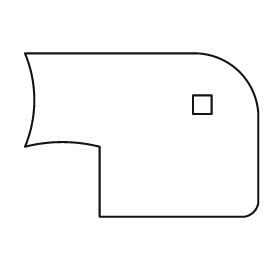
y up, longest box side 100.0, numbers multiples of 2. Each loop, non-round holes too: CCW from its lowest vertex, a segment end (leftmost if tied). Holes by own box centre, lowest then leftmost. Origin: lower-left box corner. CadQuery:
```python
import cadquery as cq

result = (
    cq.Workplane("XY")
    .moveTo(32.0, 0.0)
    .lineTo(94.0, 0.0)
    .threePointArc((98.0, 2.0), (100.0, 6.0))
    .lineTo(100.0, 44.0)
    .threePointArc((92.0, 62.0), (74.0, 70.0))
    .lineTo(0.0, 70.0)
    .threePointArc((4.0, 50.0), (0.0, 30.0))
    .threePointArc((16.0, 32.0), (32.0, 30.0))
    .close()
    .moveTo(72.0, 44.0)
    .lineTo(80.0, 44.0)
    .lineTo(80.0, 52.0)
    .lineTo(72.0, 52.0)
    .close()
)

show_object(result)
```